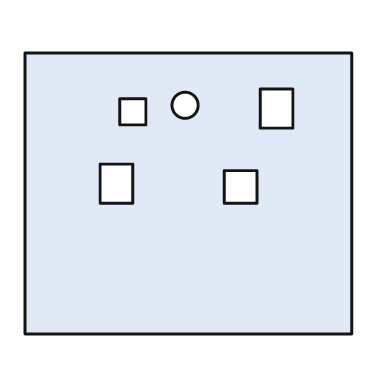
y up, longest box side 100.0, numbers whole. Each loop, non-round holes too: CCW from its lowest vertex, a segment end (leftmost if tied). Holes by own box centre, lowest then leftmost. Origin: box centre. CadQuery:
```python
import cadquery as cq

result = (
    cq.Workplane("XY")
    .moveTo(-50.0, -43.0)
    .lineTo(50.0, -43.0)
    .lineTo(50.0, 43.0)
    .lineTo(-50.0, 43.0)
    .close()
    .moveTo(11.0, -3.0)
    .lineTo(21.0, -3.0)
    .lineTo(21.0, 7.0)
    .lineTo(11.0, 7.0)
    .close()
    .moveTo(-27.0, -3.0)
    .lineTo(-17.0, -3.0)
    .lineTo(-17.0, 9.0)
    .lineTo(-27.0, 9.0)
    .close()
    .moveTo(-21.0, 21.0)
    .lineTo(-13.0, 21.0)
    .lineTo(-13.0, 29.0)
    .lineTo(-21.0, 29.0)
    .close()
    .moveTo(22.0, 20.0)
    .lineTo(32.0, 20.0)
    .lineTo(32.0, 32.0)
    .lineTo(22.0, 32.0)
    .close()
    .moveTo(-1.0, 27.0)
    .circle(4.0)
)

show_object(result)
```